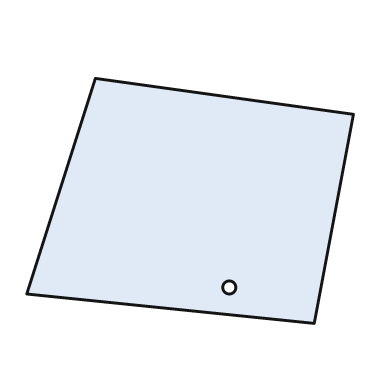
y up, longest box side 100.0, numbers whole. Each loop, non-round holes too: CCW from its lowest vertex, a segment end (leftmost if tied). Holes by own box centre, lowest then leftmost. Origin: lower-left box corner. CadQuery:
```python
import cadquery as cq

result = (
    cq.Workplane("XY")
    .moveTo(88.0, 0.0)
    .lineTo(100.0, 64.0)
    .lineTo(21.0, 75.0)
    .lineTo(0.0, 9.0)
    .close()
    .moveTo(62.0, 11.0)
    .circle(2.0)
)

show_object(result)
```